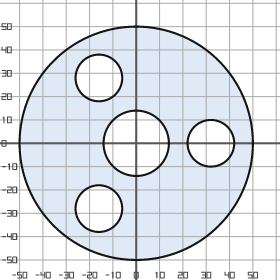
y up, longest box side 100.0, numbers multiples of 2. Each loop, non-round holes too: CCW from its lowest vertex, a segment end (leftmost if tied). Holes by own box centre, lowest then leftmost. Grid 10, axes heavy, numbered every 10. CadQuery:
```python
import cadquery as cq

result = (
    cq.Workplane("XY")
    .moveTo(0.0, 0.0)
    .circle(50.0)
    .moveTo(-16.0, -28.0)
    .circle(10.0)
    .moveTo(0.0, 0.0)
    .circle(14.0)
    .moveTo(32.0, 0.0)
    .circle(10.0)
    .moveTo(-16.0, 28.0)
    .circle(10.0)
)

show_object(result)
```